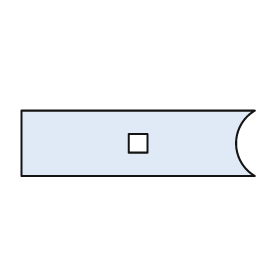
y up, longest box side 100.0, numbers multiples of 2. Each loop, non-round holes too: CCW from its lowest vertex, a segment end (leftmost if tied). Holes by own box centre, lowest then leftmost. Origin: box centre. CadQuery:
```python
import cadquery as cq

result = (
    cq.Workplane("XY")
    .moveTo(-50.0, -14.0)
    .lineTo(50.0, -14.0)
    .threePointArc((42.0, 0.0), (50.0, 14.0))
    .lineTo(-50.0, 14.0)
    .close()
    .moveTo(-4.0, -4.0)
    .lineTo(4.0, -4.0)
    .lineTo(4.0, 4.0)
    .lineTo(-4.0, 4.0)
    .close()
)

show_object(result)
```